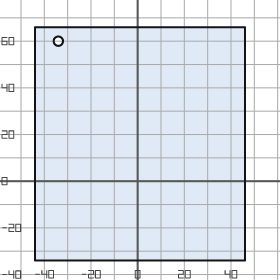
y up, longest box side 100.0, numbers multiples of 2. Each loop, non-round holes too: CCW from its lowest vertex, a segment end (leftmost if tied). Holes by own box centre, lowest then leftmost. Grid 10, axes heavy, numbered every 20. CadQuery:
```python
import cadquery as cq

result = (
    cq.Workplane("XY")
    .moveTo(-44.0, -34.0)
    .lineTo(46.0, -34.0)
    .lineTo(46.0, 66.0)
    .lineTo(-44.0, 66.0)
    .close()
    .moveTo(-34.0, 60.0)
    .circle(2.0)
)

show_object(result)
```